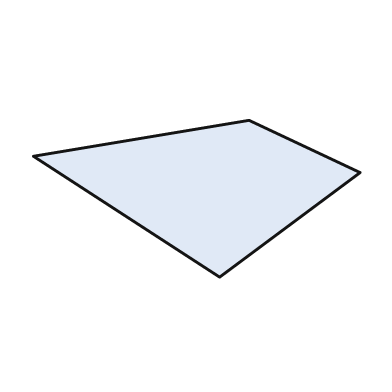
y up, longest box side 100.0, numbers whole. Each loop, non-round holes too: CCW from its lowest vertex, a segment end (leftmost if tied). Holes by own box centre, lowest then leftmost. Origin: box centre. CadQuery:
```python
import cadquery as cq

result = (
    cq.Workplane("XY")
    .moveTo(7.0, -24.0)
    .lineTo(50.0, 8.0)
    .lineTo(16.0, 24.0)
    .lineTo(-50.0, 13.0)
    .close()
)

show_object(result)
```